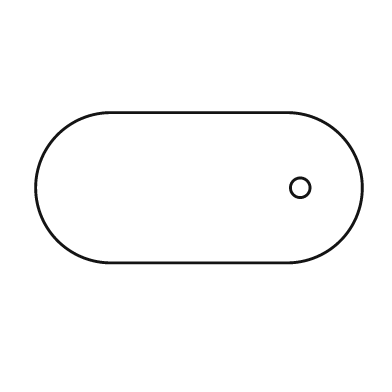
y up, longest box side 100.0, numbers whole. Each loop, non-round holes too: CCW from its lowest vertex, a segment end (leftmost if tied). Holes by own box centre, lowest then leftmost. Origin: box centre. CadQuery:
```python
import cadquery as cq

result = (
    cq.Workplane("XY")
    .moveTo(-27.0, -23.0)
    .lineTo(27.0, -23.0)
    .threePointArc((50.0, 0.0), (27.0, 23.0))
    .lineTo(-27.0, 23.0)
    .threePointArc((-50.0, 0.0), (-27.0, -23.0))
    .close()
    .moveTo(31.0, 0.0)
    .circle(3.0)
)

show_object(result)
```